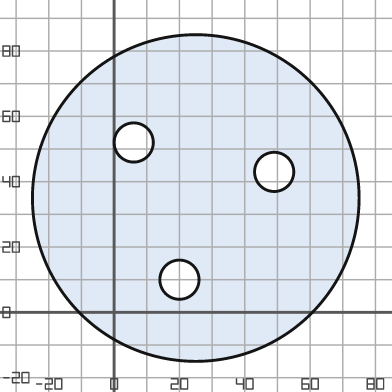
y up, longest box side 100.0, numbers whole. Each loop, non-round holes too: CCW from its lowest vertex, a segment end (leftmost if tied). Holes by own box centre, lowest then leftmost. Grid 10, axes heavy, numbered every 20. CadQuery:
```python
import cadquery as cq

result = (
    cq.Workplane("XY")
    .moveTo(25.0, 35.0)
    .circle(50.0)
    .moveTo(20.0, 10.0)
    .circle(6.0)
    .moveTo(49.0, 43.0)
    .circle(6.0)
    .moveTo(6.0, 52.0)
    .circle(6.0)
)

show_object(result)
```